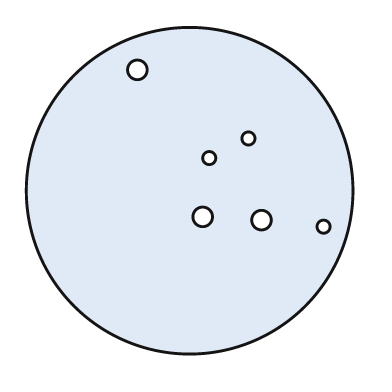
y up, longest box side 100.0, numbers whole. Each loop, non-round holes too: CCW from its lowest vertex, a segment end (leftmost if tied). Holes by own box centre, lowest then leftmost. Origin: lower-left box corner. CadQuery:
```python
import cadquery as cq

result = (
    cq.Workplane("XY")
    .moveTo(50.0, 50.0)
    .circle(50.0)
    .moveTo(91.0, 39.0)
    .circle(2.0)
    .moveTo(72.0, 41.0)
    .circle(3.0)
    .moveTo(54.0, 42.0)
    .circle(3.0)
    .moveTo(56.0, 60.0)
    .circle(2.0)
    .moveTo(68.0, 66.0)
    .circle(2.0)
    .moveTo(34.0, 87.0)
    .circle(3.0)
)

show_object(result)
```